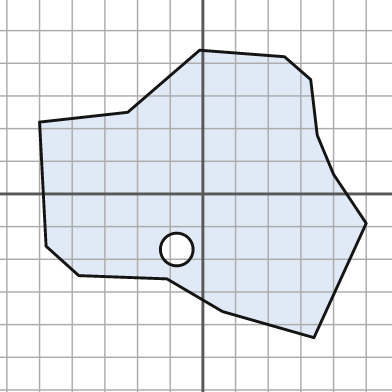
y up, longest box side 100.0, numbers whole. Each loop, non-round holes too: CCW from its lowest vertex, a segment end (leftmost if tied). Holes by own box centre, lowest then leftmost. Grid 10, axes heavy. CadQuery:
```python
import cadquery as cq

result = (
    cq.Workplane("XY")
    .moveTo(34.0, -44.0)
    .lineTo(50.0, -9.0)
    .lineTo(40.0, 6.0)
    .lineTo(35.0, 18.0)
    .lineTo(33.0, 35.0)
    .lineTo(25.0, 42.0)
    .lineTo(-1.0, 44.0)
    .lineTo(-23.0, 25.0)
    .lineTo(-50.0, 22.0)
    .lineTo(-48.0, -16.0)
    .lineTo(-38.0, -25.0)
    .lineTo(-11.0, -26.0)
    .lineTo(6.0, -36.0)
    .close()
    .moveTo(-8.0, -17.0)
    .circle(5.0)
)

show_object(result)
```